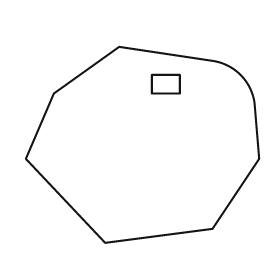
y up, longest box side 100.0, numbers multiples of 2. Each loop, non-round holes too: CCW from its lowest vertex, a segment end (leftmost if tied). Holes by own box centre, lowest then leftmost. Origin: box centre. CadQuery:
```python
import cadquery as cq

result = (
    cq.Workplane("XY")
    .moveTo(-16.0, -42.0)
    .lineTo(30.0, -36.0)
    .lineTo(50.0, -6.0)
    .lineTo(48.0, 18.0)
    .threePointArc((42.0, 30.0), (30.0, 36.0))
    .lineTo(-10.0, 42.0)
    .lineTo(-38.0, 22.0)
    .lineTo(-50.0, -6.0)
    .close()
    .moveTo(4.0, 22.0)
    .lineTo(16.0, 22.0)
    .lineTo(16.0, 30.0)
    .lineTo(4.0, 30.0)
    .close()
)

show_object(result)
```